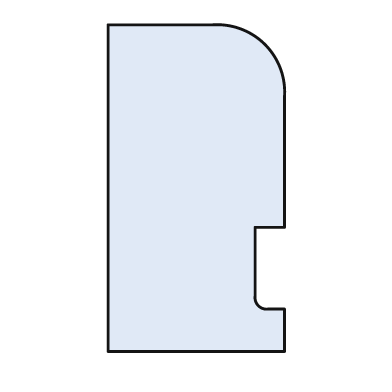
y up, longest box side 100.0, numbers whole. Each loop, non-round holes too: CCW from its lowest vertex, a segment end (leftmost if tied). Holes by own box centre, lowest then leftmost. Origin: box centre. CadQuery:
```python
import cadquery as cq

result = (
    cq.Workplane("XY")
    .moveTo(-27.0, -50.0)
    .lineTo(27.0, -50.0)
    .lineTo(27.0, -37.0)
    .lineTo(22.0, -37.0)
    .threePointArc((19.0, -36.0), (18.0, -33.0))
    .lineTo(18.0, -12.0)
    .lineTo(27.0, -12.0)
    .lineTo(27.0, 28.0)
    .threePointArc((21.0, 44.0), (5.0, 50.0))
    .lineTo(-27.0, 50.0)
    .close()
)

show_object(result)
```